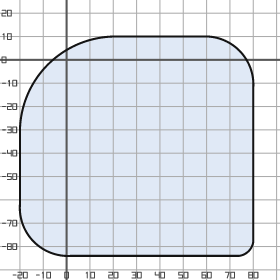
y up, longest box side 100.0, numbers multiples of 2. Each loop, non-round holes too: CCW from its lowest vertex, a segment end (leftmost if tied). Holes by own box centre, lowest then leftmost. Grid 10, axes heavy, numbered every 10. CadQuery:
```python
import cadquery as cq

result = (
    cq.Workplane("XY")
    .moveTo(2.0, -84.0)
    .lineTo(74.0, -84.0)
    .threePointArc((78.0, -82.0), (80.0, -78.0))
    .lineTo(80.0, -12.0)
    .threePointArc((74.0, 4.0), (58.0, 10.0))
    .lineTo(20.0, 10.0)
    .threePointArc((-8.0, -2.0), (-20.0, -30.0))
    .lineTo(-20.0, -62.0)
    .threePointArc((-14.0, -78.0), (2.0, -84.0))
    .close()
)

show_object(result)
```